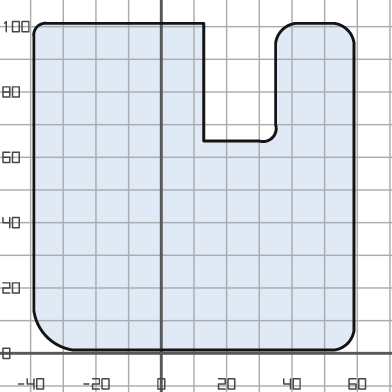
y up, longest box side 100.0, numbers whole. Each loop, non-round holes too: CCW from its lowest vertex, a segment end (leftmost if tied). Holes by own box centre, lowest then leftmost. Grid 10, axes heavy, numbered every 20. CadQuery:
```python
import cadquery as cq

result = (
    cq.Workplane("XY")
    .moveTo(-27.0, 1.0)
    .lineTo(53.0, 1.0)
    .threePointArc((57.0, 3.0), (59.0, 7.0))
    .lineTo(59.0, 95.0)
    .threePointArc((57.0, 99.0), (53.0, 101.0))
    .lineTo(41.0, 101.0)
    .threePointArc((37.0, 99.0), (35.0, 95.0))
    .lineTo(35.0, 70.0)
    .threePointArc((34.0, 66.0), (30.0, 65.0))
    .lineTo(13.0, 65.0)
    .lineTo(13.0, 101.0)
    .lineTo(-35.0, 101.0)
    .threePointArc((-38.0, 100.0), (-39.0, 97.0))
    .lineTo(-39.0, 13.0)
    .threePointArc((-35.0, 5.0), (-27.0, 1.0))
    .close()
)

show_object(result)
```